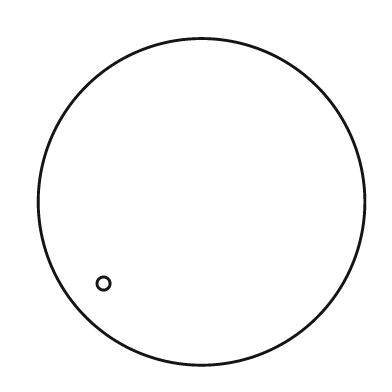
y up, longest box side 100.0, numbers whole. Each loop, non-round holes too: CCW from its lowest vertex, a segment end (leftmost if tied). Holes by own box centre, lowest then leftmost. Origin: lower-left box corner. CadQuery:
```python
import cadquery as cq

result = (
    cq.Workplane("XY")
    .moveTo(50.0, 50.0)
    .circle(50.0)
    .moveTo(20.0, 25.0)
    .circle(2.0)
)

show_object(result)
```